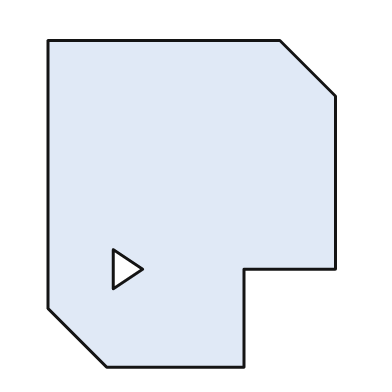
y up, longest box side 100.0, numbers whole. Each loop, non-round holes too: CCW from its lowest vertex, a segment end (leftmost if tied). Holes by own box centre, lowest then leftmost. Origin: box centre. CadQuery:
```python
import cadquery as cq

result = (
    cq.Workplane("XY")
    .moveTo(-26.0, -50.0)
    .lineTo(16.0, -50.0)
    .lineTo(16.0, -20.0)
    .lineTo(44.0, -20.0)
    .lineTo(44.0, 33.0)
    .lineTo(27.0, 50.0)
    .lineTo(-44.0, 50.0)
    .lineTo(-44.0, -32.0)
    .close()
    .moveTo(-24.0, -26.0)
    .lineTo(-15.0, -20.0)
    .lineTo(-24.0, -14.0)
    .close()
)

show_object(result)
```